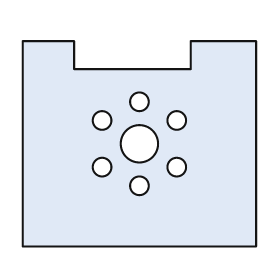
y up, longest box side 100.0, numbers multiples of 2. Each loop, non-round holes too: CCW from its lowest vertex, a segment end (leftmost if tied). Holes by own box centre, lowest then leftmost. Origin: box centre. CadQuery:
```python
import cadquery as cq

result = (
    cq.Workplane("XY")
    .moveTo(-50.0, -44.0)
    .lineTo(50.0, -44.0)
    .lineTo(50.0, 44.0)
    .lineTo(22.0, 44.0)
    .lineTo(22.0, 32.0)
    .lineTo(-28.0, 32.0)
    .lineTo(-28.0, 44.0)
    .lineTo(-50.0, 44.0)
    .close()
    .moveTo(0.0, -18.0)
    .circle(4.0)
    .moveTo(-16.0, -10.0)
    .circle(4.0)
    .moveTo(16.0, -10.0)
    .circle(4.0)
    .moveTo(0.0, 0.0)
    .circle(8.0)
    .moveTo(-16.0, 10.0)
    .circle(4.0)
    .moveTo(16.0, 10.0)
    .circle(4.0)
    .moveTo(0.0, 18.0)
    .circle(4.0)
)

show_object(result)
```